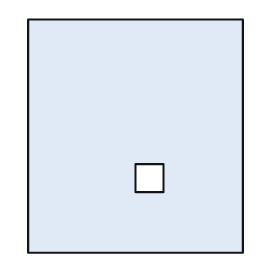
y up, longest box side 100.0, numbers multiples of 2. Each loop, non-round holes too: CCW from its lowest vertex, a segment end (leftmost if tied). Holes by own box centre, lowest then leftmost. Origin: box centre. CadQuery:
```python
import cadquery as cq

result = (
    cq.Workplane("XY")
    .moveTo(-46.0, -50.0)
    .lineTo(46.0, -50.0)
    .lineTo(46.0, 50.0)
    .lineTo(-46.0, 50.0)
    .close()
    .moveTo(0.0, -24.0)
    .lineTo(12.0, -24.0)
    .lineTo(12.0, -12.0)
    .lineTo(0.0, -12.0)
    .close()
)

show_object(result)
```